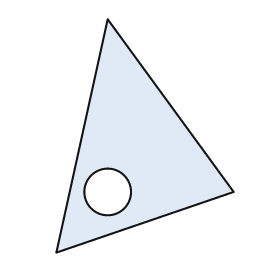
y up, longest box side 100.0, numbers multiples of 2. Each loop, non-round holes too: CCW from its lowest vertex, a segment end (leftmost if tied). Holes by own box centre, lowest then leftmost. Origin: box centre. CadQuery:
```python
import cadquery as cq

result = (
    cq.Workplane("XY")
    .moveTo(-38.0, -50.0)
    .lineTo(38.0, -24.0)
    .lineTo(-16.0, 50.0)
    .close()
    .moveTo(-16.0, -24.0)
    .circle(10.0)
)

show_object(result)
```